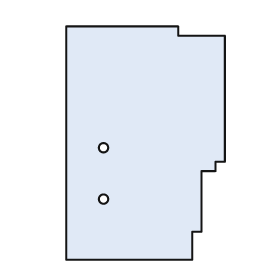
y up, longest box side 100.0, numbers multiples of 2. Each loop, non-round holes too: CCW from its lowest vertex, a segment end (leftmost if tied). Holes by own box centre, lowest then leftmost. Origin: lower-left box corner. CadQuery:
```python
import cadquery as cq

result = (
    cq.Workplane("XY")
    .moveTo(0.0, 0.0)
    .lineTo(54.0, 0.0)
    .lineTo(54.0, 12.0)
    .lineTo(58.0, 12.0)
    .lineTo(58.0, 38.0)
    .lineTo(64.0, 38.0)
    .lineTo(64.0, 42.0)
    .lineTo(68.0, 42.0)
    .lineTo(68.0, 96.0)
    .lineTo(48.0, 96.0)
    .lineTo(48.0, 100.0)
    .lineTo(0.0, 100.0)
    .close()
    .moveTo(16.0, 26.0)
    .circle(2.0)
    .moveTo(16.0, 48.0)
    .circle(2.0)
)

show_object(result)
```